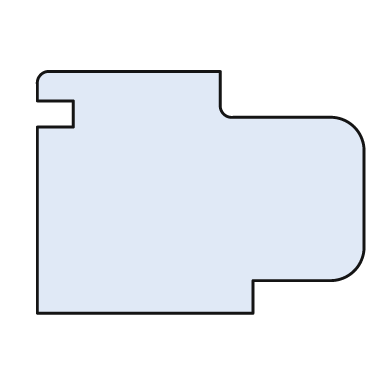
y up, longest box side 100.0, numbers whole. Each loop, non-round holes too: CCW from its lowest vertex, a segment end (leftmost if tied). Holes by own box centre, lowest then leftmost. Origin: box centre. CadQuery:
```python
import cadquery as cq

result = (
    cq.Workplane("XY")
    .moveTo(-50.0, -37.0)
    .lineTo(16.0, -37.0)
    .lineTo(16.0, -27.0)
    .lineTo(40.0, -27.0)
    .threePointArc((47.0, -24.0), (50.0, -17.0))
    .lineTo(50.0, 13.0)
    .threePointArc((47.0, 20.0), (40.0, 23.0))
    .lineTo(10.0, 23.0)
    .threePointArc((7.0, 24.0), (6.0, 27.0))
    .lineTo(6.0, 37.0)
    .lineTo(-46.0, 37.0)
    .threePointArc((-49.0, 36.0), (-50.0, 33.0))
    .lineTo(-50.0, 28.0)
    .lineTo(-39.0, 28.0)
    .lineTo(-39.0, 20.0)
    .lineTo(-50.0, 20.0)
    .close()
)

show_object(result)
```